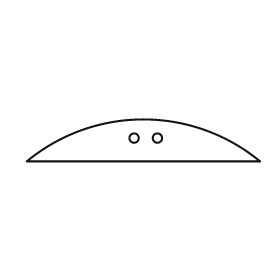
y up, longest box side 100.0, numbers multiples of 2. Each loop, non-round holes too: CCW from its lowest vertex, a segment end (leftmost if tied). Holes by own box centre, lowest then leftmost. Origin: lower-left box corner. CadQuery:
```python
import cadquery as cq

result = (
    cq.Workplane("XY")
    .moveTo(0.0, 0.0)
    .lineTo(100.0, 0.0)
    .threePointArc((50.0, 18.0), (0.0, 0.0))
    .close()
    .moveTo(46.0, 10.0)
    .circle(2.0)
    .moveTo(56.0, 10.0)
    .circle(2.0)
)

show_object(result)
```